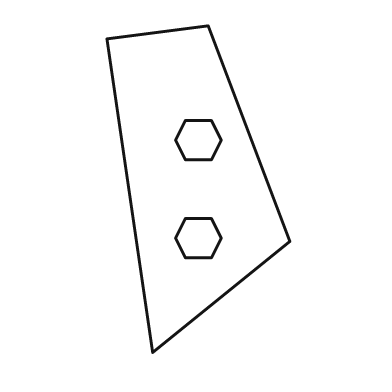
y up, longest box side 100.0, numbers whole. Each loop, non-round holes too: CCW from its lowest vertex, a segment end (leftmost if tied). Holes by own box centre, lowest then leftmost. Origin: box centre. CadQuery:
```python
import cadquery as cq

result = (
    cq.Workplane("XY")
    .moveTo(-14.0, -50.0)
    .lineTo(28.0, -16.0)
    .lineTo(3.0, 50.0)
    .lineTo(-28.0, 46.0)
    .close()
    .moveTo(-4.0, -21.0)
    .lineTo(4.0, -21.0)
    .lineTo(7.0, -15.0)
    .lineTo(4.0, -9.0)
    .lineTo(-4.0, -9.0)
    .lineTo(-7.0, -15.0)
    .close()
    .moveTo(-4.0, 9.0)
    .lineTo(4.0, 9.0)
    .lineTo(7.0, 15.0)
    .lineTo(4.0, 21.0)
    .lineTo(-4.0, 21.0)
    .lineTo(-7.0, 15.0)
    .close()
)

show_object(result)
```